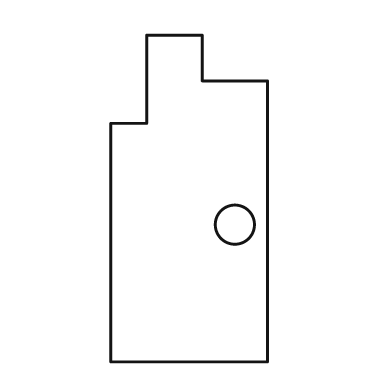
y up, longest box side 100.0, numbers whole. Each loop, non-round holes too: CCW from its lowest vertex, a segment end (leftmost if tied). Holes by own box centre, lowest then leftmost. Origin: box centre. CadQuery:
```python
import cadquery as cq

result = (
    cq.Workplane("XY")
    .moveTo(-24.0, -50.0)
    .lineTo(24.0, -50.0)
    .lineTo(24.0, 36.0)
    .lineTo(4.0, 36.0)
    .lineTo(4.0, 50.0)
    .lineTo(-13.0, 50.0)
    .lineTo(-13.0, 23.0)
    .lineTo(-24.0, 23.0)
    .close()
    .moveTo(14.0, -8.0)
    .circle(6.0)
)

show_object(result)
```